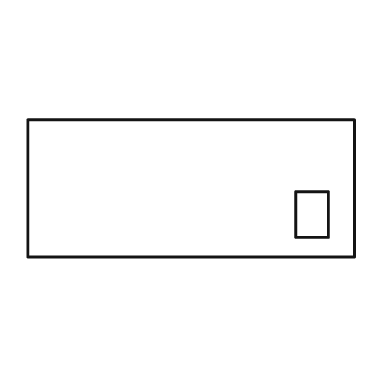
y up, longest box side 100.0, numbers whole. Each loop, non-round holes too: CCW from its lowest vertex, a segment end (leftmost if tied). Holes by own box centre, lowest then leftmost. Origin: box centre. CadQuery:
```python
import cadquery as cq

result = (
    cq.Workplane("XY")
    .moveTo(-50.0, -21.0)
    .lineTo(50.0, -21.0)
    .lineTo(50.0, 21.0)
    .lineTo(-50.0, 21.0)
    .close()
    .moveTo(32.0, -15.0)
    .lineTo(42.0, -15.0)
    .lineTo(42.0, -1.0)
    .lineTo(32.0, -1.0)
    .close()
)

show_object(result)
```